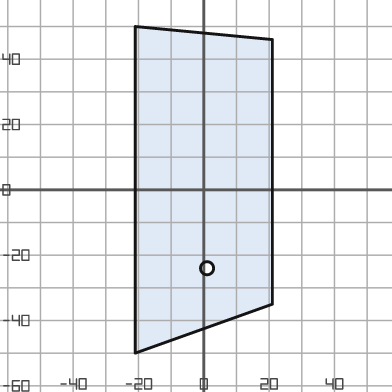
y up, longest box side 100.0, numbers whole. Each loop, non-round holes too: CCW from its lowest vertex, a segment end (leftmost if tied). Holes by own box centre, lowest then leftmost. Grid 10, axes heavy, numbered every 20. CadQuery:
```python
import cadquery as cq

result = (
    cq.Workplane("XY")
    .moveTo(-21.0, -50.0)
    .lineTo(21.0, -35.0)
    .lineTo(21.0, 46.0)
    .lineTo(-21.0, 50.0)
    .close()
    .moveTo(1.0, -24.0)
    .circle(2.0)
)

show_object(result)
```